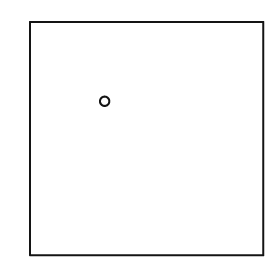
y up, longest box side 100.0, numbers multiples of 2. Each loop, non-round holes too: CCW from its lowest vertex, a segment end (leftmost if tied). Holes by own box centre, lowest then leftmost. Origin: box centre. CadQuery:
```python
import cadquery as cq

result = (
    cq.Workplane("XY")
    .moveTo(-50.0, -50.0)
    .lineTo(50.0, -50.0)
    .lineTo(50.0, 50.0)
    .lineTo(-50.0, 50.0)
    .close()
    .moveTo(-18.0, 16.0)
    .circle(2.0)
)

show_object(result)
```